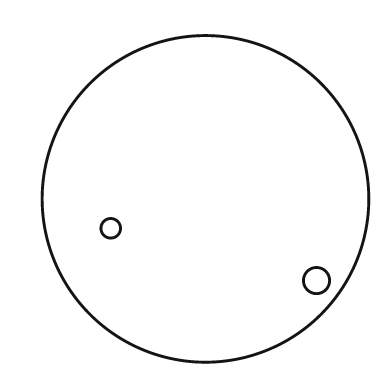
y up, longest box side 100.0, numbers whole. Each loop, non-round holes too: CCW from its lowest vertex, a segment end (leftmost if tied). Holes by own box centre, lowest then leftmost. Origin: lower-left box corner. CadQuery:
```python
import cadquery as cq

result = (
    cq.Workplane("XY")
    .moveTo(50.0, 50.0)
    .circle(50.0)
    .moveTo(84.0, 25.0)
    .circle(4.0)
    .moveTo(21.0, 41.0)
    .circle(3.0)
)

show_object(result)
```